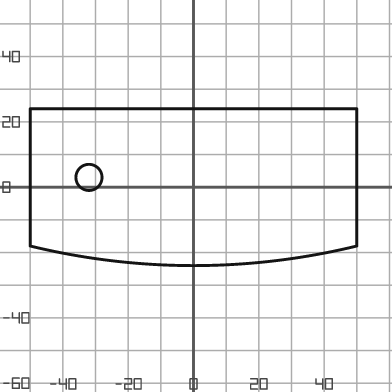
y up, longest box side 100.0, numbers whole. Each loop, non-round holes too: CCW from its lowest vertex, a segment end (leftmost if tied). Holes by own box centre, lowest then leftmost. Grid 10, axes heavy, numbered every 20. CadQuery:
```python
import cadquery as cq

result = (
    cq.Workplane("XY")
    .moveTo(-50.0, -18.0)
    .threePointArc((0.0, -24.0), (50.0, -18.0))
    .lineTo(50.0, 24.0)
    .lineTo(-50.0, 24.0)
    .close()
    .moveTo(-32.0, 3.0)
    .circle(4.0)
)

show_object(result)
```